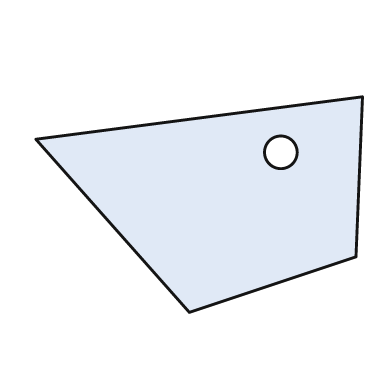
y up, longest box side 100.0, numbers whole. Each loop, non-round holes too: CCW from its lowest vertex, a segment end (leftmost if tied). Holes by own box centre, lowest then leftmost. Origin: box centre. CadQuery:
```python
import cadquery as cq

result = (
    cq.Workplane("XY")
    .moveTo(-3.0, -33.0)
    .lineTo(48.0, -16.0)
    .lineTo(50.0, 33.0)
    .lineTo(-50.0, 20.0)
    .close()
    .moveTo(25.0, 16.0)
    .circle(5.0)
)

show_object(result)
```